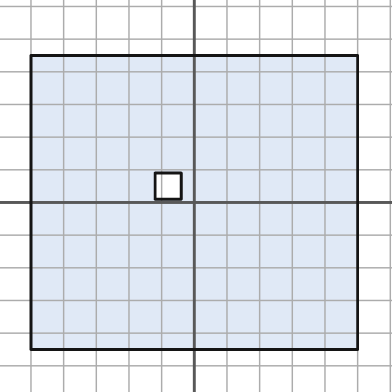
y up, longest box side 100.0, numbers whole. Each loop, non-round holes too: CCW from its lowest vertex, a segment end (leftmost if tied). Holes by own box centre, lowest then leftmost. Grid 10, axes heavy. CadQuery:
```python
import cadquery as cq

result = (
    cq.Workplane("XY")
    .moveTo(-50.0, -45.0)
    .lineTo(50.0, -45.0)
    .lineTo(50.0, 45.0)
    .lineTo(-50.0, 45.0)
    .close()
    .moveTo(-12.0, 1.0)
    .lineTo(-4.0, 1.0)
    .lineTo(-4.0, 9.0)
    .lineTo(-12.0, 9.0)
    .close()
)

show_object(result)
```